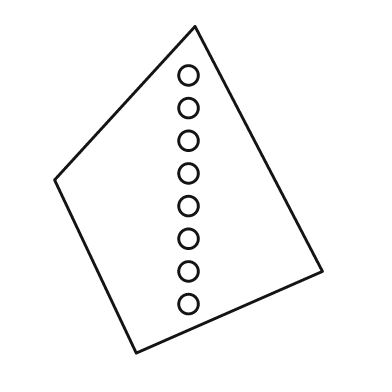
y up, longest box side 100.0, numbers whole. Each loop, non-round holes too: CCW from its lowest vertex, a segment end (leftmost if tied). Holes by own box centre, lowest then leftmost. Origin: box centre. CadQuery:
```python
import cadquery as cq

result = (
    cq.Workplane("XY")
    .moveTo(-16.0, -50.0)
    .lineTo(41.0, -25.0)
    .lineTo(2.0, 50.0)
    .lineTo(-41.0, 3.0)
    .close()
    .moveTo(0.0, -35.0)
    .circle(3.0)
    .moveTo(0.0, -25.0)
    .circle(3.0)
    .moveTo(0.0, -15.0)
    .circle(3.0)
    .moveTo(0.0, -5.0)
    .circle(3.0)
    .moveTo(0.0, 5.0)
    .circle(3.0)
    .moveTo(0.0, 15.0)
    .circle(3.0)
    .moveTo(0.0, 25.0)
    .circle(3.0)
    .moveTo(0.0, 35.0)
    .circle(3.0)
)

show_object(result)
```